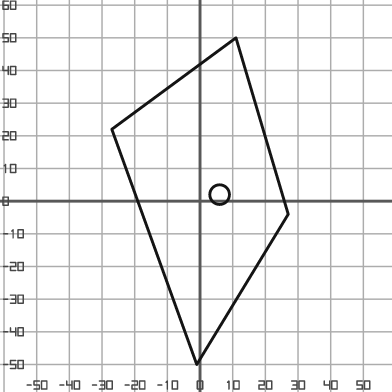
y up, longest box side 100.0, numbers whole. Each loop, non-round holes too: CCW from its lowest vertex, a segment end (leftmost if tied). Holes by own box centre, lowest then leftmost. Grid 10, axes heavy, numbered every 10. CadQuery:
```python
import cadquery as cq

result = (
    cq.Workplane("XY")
    .moveTo(-1.0, -50.0)
    .lineTo(27.0, -4.0)
    .lineTo(11.0, 50.0)
    .lineTo(-27.0, 22.0)
    .close()
    .moveTo(6.0, 2.0)
    .circle(3.0)
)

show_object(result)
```